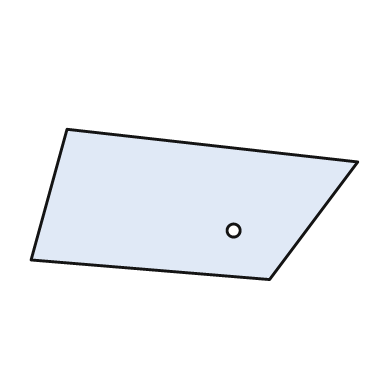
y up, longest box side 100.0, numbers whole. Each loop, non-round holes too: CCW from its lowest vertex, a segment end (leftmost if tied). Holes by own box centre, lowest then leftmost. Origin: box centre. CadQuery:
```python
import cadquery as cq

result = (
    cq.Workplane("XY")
    .moveTo(23.0, -23.0)
    .lineTo(50.0, 13.0)
    .lineTo(-39.0, 23.0)
    .lineTo(-50.0, -17.0)
    .close()
    .moveTo(12.0, -8.0)
    .circle(2.0)
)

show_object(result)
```